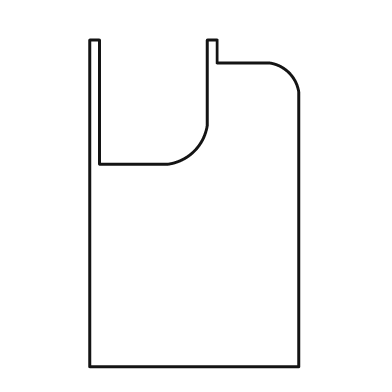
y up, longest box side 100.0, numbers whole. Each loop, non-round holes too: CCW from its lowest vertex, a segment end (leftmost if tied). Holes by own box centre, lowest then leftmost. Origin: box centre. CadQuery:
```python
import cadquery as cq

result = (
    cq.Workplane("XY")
    .moveTo(-32.0, -50.0)
    .lineTo(32.0, -50.0)
    .lineTo(32.0, 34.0)
    .threePointArc((29.0, 40.0), (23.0, 43.0))
    .lineTo(7.0, 43.0)
    .lineTo(7.0, 50.0)
    .lineTo(4.0, 50.0)
    .lineTo(4.0, 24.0)
    .threePointArc((0.0, 16.0), (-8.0, 12.0))
    .lineTo(-29.0, 12.0)
    .lineTo(-29.0, 50.0)
    .lineTo(-32.0, 50.0)
    .close()
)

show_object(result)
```